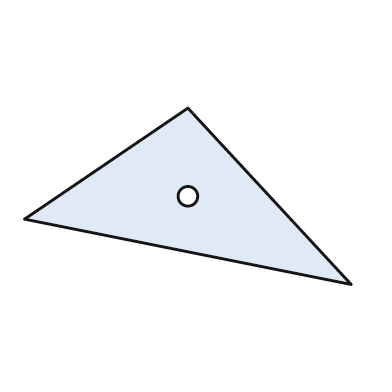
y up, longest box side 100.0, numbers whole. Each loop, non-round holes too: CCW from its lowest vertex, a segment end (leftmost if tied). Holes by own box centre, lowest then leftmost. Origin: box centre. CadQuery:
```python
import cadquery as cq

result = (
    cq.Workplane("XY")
    .moveTo(50.0, -27.0)
    .lineTo(0.0, 27.0)
    .lineTo(-50.0, -7.0)
    .close()
    .moveTo(0.0, 0.0)
    .circle(3.0)
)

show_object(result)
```